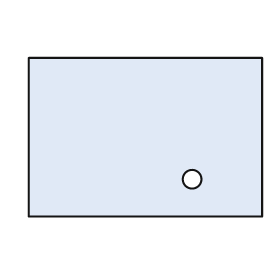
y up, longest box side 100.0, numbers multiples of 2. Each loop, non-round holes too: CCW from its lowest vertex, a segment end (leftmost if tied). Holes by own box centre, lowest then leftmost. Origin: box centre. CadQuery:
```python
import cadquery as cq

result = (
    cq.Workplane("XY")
    .moveTo(-50.0, -34.0)
    .lineTo(50.0, -34.0)
    .lineTo(50.0, 34.0)
    .lineTo(-50.0, 34.0)
    .close()
    .moveTo(20.0, -18.0)
    .circle(4.0)
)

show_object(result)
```